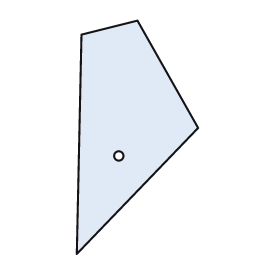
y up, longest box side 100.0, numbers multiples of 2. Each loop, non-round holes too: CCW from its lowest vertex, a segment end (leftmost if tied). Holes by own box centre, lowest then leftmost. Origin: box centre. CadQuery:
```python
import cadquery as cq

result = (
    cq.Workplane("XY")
    .moveTo(-26.0, -50.0)
    .lineTo(26.0, 4.0)
    .lineTo(0.0, 50.0)
    .lineTo(-24.0, 44.0)
    .close()
    .moveTo(-8.0, -8.0)
    .circle(2.0)
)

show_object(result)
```